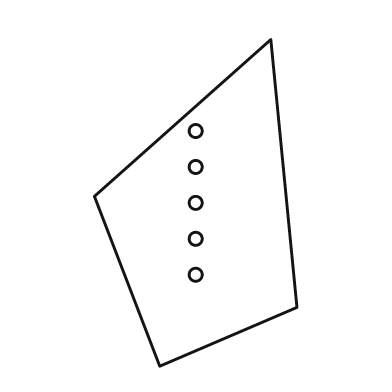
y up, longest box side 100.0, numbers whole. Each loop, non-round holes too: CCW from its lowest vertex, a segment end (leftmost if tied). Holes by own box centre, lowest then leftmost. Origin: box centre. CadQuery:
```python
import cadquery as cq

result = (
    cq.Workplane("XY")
    .moveTo(-11.0, -50.0)
    .lineTo(31.0, -32.0)
    .lineTo(23.0, 50.0)
    .lineTo(-31.0, 2.0)
    .close()
    .moveTo(0.0, -22.0)
    .circle(2.0)
    .moveTo(0.0, -11.0)
    .circle(2.0)
    .moveTo(0.0, 0.0)
    .circle(2.0)
    .moveTo(0.0, 11.0)
    .circle(2.0)
    .moveTo(0.0, 22.0)
    .circle(2.0)
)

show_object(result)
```